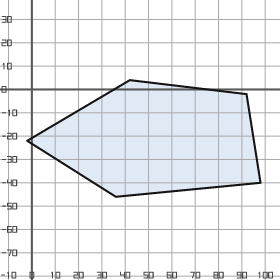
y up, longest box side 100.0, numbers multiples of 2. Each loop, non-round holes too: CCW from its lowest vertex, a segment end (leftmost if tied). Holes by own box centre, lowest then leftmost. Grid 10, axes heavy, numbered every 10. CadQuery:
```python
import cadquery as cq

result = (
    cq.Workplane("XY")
    .moveTo(36.0, -46.0)
    .lineTo(98.0, -40.0)
    .lineTo(92.0, -2.0)
    .lineTo(42.0, 4.0)
    .lineTo(-2.0, -22.0)
    .close()
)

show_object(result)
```